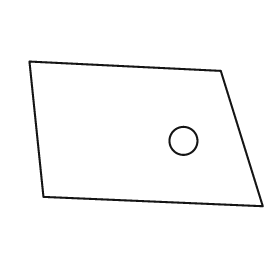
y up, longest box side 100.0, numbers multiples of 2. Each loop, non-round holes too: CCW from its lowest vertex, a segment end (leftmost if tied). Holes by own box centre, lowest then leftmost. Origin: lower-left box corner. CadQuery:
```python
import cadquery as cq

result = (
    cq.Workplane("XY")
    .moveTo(100.0, 0.0)
    .lineTo(82.0, 58.0)
    .lineTo(0.0, 62.0)
    .lineTo(6.0, 4.0)
    .close()
    .moveTo(66.0, 28.0)
    .circle(6.0)
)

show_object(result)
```